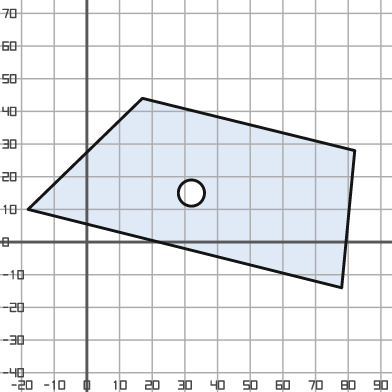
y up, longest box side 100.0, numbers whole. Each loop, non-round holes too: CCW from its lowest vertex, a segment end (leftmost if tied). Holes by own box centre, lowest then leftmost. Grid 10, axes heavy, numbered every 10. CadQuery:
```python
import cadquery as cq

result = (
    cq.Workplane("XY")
    .moveTo(78.0, -14.0)
    .lineTo(82.0, 28.0)
    .lineTo(17.0, 44.0)
    .lineTo(-18.0, 10.0)
    .close()
    .moveTo(32.0, 15.0)
    .circle(4.0)
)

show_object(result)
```